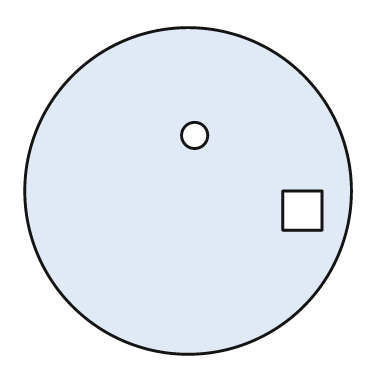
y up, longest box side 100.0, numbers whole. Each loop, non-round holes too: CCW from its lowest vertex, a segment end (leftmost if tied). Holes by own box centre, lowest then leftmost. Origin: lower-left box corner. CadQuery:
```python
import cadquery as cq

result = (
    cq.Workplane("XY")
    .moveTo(50.0, 50.0)
    .circle(50.0)
    .moveTo(79.0, 38.0)
    .lineTo(91.0, 38.0)
    .lineTo(91.0, 50.0)
    .lineTo(79.0, 50.0)
    .close()
    .moveTo(52.0, 67.0)
    .circle(4.0)
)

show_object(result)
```